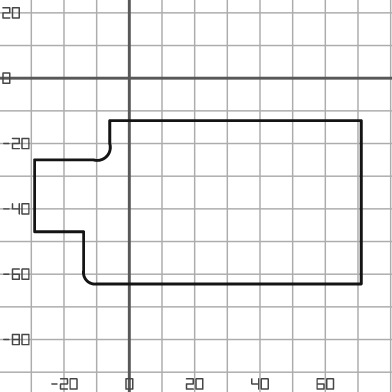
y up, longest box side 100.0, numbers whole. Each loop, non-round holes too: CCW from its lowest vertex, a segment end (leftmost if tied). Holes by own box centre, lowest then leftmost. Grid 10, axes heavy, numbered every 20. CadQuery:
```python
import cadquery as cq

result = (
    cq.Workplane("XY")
    .moveTo(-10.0, -63.0)
    .lineTo(71.0, -63.0)
    .lineTo(71.0, -13.0)
    .lineTo(-6.0, -13.0)
    .lineTo(-6.0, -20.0)
    .threePointArc((-7.0, -24.0), (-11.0, -25.0))
    .lineTo(-29.0, -25.0)
    .lineTo(-29.0, -47.0)
    .lineTo(-14.0, -47.0)
    .lineTo(-14.0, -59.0)
    .threePointArc((-13.0, -62.0), (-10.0, -63.0))
    .close()
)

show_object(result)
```